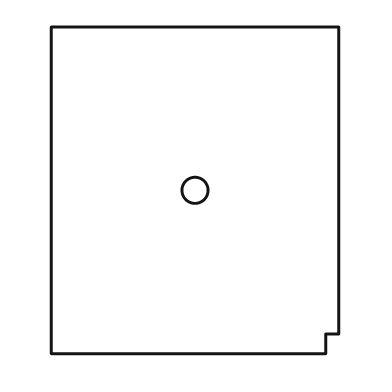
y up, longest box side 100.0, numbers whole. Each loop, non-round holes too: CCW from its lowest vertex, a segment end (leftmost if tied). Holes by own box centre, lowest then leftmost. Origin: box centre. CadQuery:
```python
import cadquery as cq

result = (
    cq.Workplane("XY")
    .moveTo(-44.0, -50.0)
    .lineTo(40.0, -50.0)
    .lineTo(40.0, -44.0)
    .lineTo(44.0, -44.0)
    .lineTo(44.0, 50.0)
    .lineTo(-44.0, 50.0)
    .close()
    .moveTo(0.0, 0.0)
    .circle(4.0)
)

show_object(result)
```